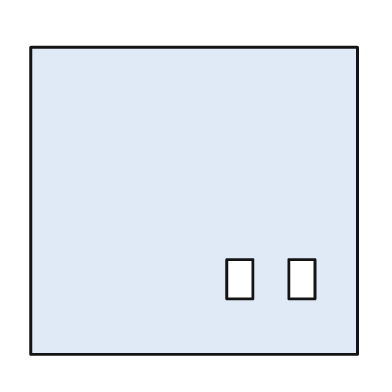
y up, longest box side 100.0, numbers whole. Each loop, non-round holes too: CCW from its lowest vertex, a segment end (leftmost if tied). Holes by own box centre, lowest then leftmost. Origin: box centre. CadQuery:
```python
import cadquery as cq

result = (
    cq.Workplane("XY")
    .moveTo(-50.0, -47.0)
    .lineTo(50.0, -47.0)
    .lineTo(50.0, 47.0)
    .lineTo(-50.0, 47.0)
    .close()
    .moveTo(10.0, -30.0)
    .lineTo(18.0, -30.0)
    .lineTo(18.0, -18.0)
    .lineTo(10.0, -18.0)
    .close()
    .moveTo(29.0, -30.0)
    .lineTo(37.0, -30.0)
    .lineTo(37.0, -18.0)
    .lineTo(29.0, -18.0)
    .close()
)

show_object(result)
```